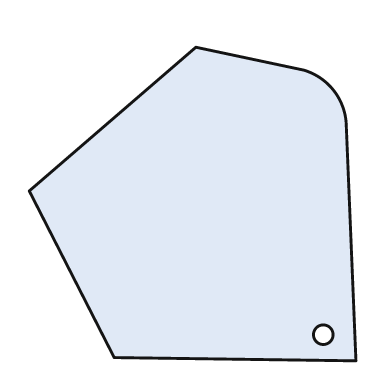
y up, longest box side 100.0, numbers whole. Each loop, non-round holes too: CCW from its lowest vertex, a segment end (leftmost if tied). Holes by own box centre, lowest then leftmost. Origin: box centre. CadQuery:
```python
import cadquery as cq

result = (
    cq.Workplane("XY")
    .moveTo(50.0, -48.0)
    .lineTo(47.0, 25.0)
    .threePointArc((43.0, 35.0), (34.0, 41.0))
    .lineTo(1.0, 48.0)
    .lineTo(-50.0, 4.0)
    .lineTo(-24.0, -47.0)
    .close()
    .moveTo(40.0, -40.0)
    .circle(3.0)
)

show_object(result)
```